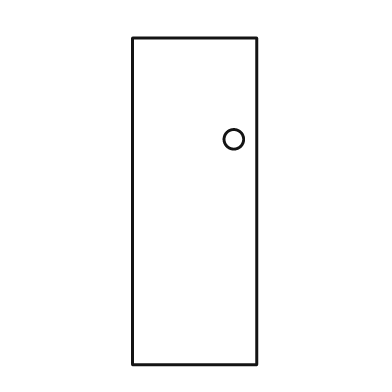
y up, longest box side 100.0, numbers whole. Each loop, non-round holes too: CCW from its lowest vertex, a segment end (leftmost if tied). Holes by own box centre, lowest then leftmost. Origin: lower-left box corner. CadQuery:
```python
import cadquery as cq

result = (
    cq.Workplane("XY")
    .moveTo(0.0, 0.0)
    .lineTo(38.0, 0.0)
    .lineTo(38.0, 100.0)
    .lineTo(0.0, 100.0)
    .close()
    .moveTo(31.0, 69.0)
    .circle(3.0)
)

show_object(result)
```